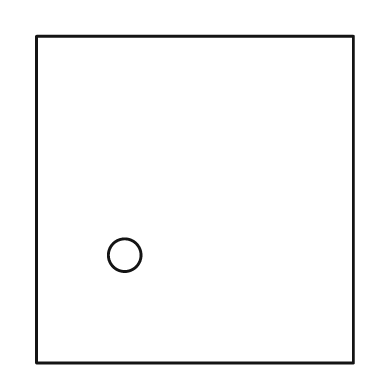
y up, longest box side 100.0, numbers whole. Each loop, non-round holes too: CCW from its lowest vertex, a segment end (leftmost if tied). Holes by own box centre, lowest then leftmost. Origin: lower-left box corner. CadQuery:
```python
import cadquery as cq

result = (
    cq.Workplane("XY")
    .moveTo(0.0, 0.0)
    .lineTo(97.0, 0.0)
    .lineTo(97.0, 100.0)
    .lineTo(0.0, 100.0)
    .close()
    .moveTo(27.0, 33.0)
    .circle(5.0)
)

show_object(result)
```